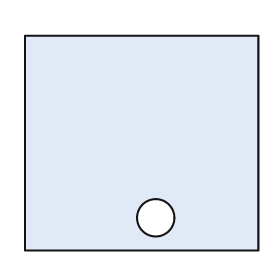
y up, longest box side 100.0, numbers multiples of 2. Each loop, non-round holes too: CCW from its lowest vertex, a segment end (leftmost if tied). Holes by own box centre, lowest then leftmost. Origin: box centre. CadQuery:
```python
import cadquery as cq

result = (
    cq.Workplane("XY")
    .moveTo(-50.0, -46.0)
    .lineTo(50.0, -46.0)
    .lineTo(50.0, 46.0)
    .lineTo(-50.0, 46.0)
    .close()
    .moveTo(6.0, -32.0)
    .circle(8.0)
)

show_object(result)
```